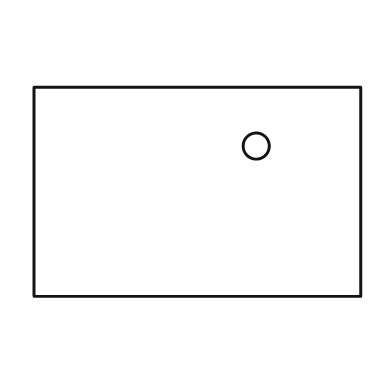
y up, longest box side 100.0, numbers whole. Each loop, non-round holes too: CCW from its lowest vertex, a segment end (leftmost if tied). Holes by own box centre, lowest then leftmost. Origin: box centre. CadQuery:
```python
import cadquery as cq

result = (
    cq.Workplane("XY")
    .moveTo(-50.0, -32.0)
    .lineTo(50.0, -32.0)
    .lineTo(50.0, 32.0)
    .lineTo(-50.0, 32.0)
    .close()
    .moveTo(18.0, 14.0)
    .circle(4.0)
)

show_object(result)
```